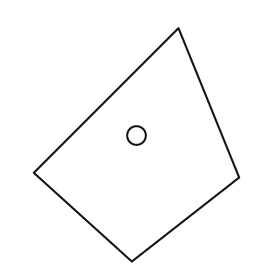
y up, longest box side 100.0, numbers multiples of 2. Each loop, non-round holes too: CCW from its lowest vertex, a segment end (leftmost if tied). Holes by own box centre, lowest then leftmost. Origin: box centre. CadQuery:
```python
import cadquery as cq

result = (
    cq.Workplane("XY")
    .moveTo(-2.0, -50.0)
    .lineTo(44.0, -14.0)
    .lineTo(18.0, 50.0)
    .lineTo(-44.0, -12.0)
    .close()
    .moveTo(0.0, 4.0)
    .circle(4.0)
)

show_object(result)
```